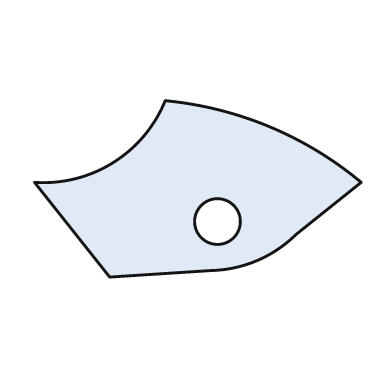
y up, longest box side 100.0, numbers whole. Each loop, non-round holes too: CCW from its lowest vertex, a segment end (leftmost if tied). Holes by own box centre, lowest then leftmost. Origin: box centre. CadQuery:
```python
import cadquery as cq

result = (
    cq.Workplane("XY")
    .moveTo(-27.0, -27.0)
    .lineTo(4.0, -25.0)
    .threePointArc((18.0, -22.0), (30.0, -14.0))
    .lineTo(50.0, 2.0)
    .threePointArc((22.0, 19.0), (-10.0, 27.0))
    .threePointArc((-26.0, 8.0), (-50.0, 2.0))
    .close()
    .moveTo(6.0, -10.0)
    .circle(7.0)
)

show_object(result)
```